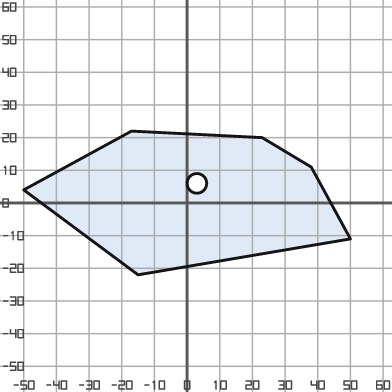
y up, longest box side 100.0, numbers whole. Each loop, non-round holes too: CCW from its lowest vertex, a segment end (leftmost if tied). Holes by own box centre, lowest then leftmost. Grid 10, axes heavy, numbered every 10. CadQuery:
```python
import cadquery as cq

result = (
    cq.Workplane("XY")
    .moveTo(-15.0, -22.0)
    .lineTo(50.0, -11.0)
    .lineTo(38.0, 11.0)
    .lineTo(23.0, 20.0)
    .lineTo(-17.0, 22.0)
    .lineTo(-50.0, 4.0)
    .close()
    .moveTo(3.0, 6.0)
    .circle(3.0)
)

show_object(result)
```